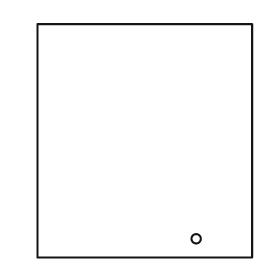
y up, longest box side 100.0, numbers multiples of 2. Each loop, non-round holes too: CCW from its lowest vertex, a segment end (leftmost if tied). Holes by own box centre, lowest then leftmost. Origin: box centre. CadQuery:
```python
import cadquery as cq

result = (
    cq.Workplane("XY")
    .moveTo(-46.0, -50.0)
    .lineTo(46.0, -50.0)
    .lineTo(46.0, 50.0)
    .lineTo(-46.0, 50.0)
    .close()
    .moveTo(22.0, -42.0)
    .circle(2.0)
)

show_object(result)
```